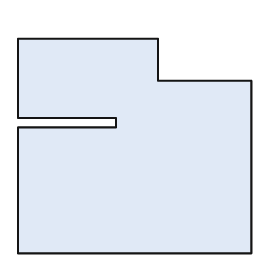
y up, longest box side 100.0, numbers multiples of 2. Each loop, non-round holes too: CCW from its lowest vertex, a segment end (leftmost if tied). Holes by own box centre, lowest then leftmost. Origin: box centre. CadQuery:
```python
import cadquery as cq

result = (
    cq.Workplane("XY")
    .moveTo(-50.0, -46.0)
    .lineTo(50.0, -46.0)
    .lineTo(50.0, 28.0)
    .lineTo(10.0, 28.0)
    .lineTo(10.0, 46.0)
    .lineTo(-50.0, 46.0)
    .lineTo(-50.0, 12.0)
    .lineTo(-8.0, 12.0)
    .lineTo(-8.0, 8.0)
    .lineTo(-50.0, 8.0)
    .close()
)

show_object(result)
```